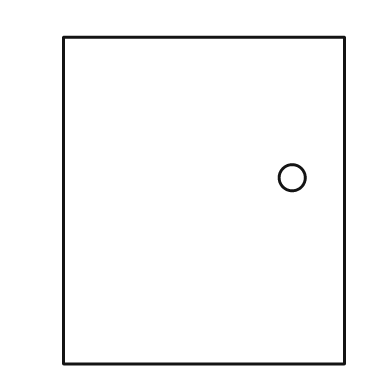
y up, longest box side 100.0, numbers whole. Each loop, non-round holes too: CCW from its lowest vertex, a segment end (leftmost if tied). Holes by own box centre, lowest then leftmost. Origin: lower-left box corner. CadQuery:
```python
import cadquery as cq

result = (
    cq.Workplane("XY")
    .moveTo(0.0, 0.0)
    .lineTo(86.0, 0.0)
    .lineTo(86.0, 100.0)
    .lineTo(0.0, 100.0)
    .close()
    .moveTo(70.0, 57.0)
    .circle(4.0)
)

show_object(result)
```